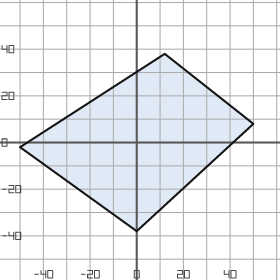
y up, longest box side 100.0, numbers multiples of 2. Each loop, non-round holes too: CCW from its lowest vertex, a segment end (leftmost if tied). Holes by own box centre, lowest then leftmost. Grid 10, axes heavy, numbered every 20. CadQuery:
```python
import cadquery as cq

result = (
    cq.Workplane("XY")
    .moveTo(0.0, -38.0)
    .lineTo(50.0, 8.0)
    .lineTo(12.0, 38.0)
    .lineTo(-50.0, -2.0)
    .close()
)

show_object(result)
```